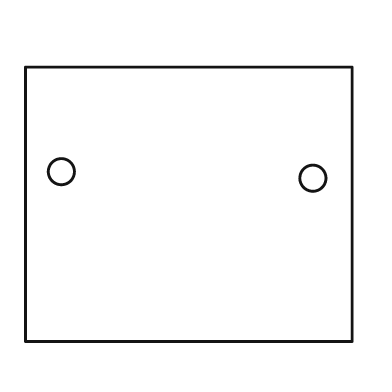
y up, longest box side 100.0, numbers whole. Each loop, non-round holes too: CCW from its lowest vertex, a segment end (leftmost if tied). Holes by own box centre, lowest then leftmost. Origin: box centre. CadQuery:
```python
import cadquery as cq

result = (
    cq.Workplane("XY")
    .moveTo(-50.0, -42.0)
    .lineTo(50.0, -42.0)
    .lineTo(50.0, 42.0)
    .lineTo(-50.0, 42.0)
    .close()
    .moveTo(38.0, 8.0)
    .circle(4.0)
    .moveTo(-39.0, 10.0)
    .circle(4.0)
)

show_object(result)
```